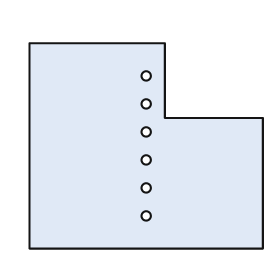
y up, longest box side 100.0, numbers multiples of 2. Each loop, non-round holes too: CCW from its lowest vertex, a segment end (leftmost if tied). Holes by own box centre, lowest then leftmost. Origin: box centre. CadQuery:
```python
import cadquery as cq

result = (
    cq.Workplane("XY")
    .moveTo(-50.0, -44.0)
    .lineTo(50.0, -44.0)
    .lineTo(50.0, 12.0)
    .lineTo(8.0, 12.0)
    .lineTo(8.0, 44.0)
    .lineTo(-50.0, 44.0)
    .close()
    .moveTo(0.0, -30.0)
    .circle(2.0)
    .moveTo(0.0, -18.0)
    .circle(2.0)
    .moveTo(0.0, -6.0)
    .circle(2.0)
    .moveTo(0.0, 6.0)
    .circle(2.0)
    .moveTo(0.0, 18.0)
    .circle(2.0)
    .moveTo(0.0, 30.0)
    .circle(2.0)
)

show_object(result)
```